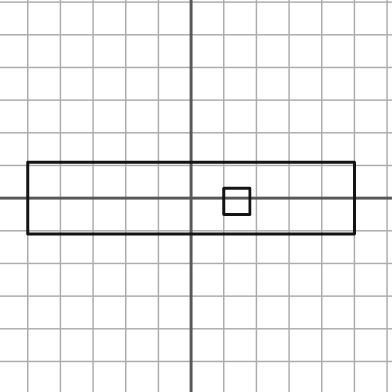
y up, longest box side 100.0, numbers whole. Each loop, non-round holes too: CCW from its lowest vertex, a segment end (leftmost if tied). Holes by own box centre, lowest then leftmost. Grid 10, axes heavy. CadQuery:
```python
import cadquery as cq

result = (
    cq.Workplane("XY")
    .moveTo(-50.0, -11.0)
    .lineTo(50.0, -11.0)
    .lineTo(50.0, 11.0)
    .lineTo(-50.0, 11.0)
    .close()
    .moveTo(10.0, -5.0)
    .lineTo(18.0, -5.0)
    .lineTo(18.0, 3.0)
    .lineTo(10.0, 3.0)
    .close()
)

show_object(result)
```